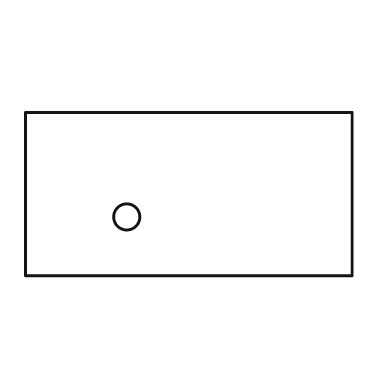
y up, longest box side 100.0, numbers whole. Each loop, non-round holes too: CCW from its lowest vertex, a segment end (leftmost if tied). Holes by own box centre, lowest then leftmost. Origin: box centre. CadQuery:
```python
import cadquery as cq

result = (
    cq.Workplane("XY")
    .moveTo(-50.0, -25.0)
    .lineTo(50.0, -25.0)
    .lineTo(50.0, 25.0)
    .lineTo(-50.0, 25.0)
    .close()
    .moveTo(-19.0, -7.0)
    .circle(4.0)
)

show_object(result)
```